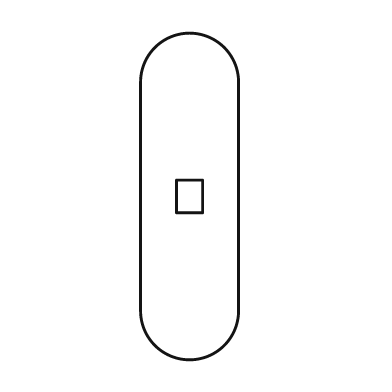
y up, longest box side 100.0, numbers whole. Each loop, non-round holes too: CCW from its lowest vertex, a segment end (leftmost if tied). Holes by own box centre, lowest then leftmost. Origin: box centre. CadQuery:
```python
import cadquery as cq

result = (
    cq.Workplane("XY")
    .moveTo(-15.0, -35.0)
    .threePointArc((0.0, -50.0), (15.0, -35.0))
    .lineTo(15.0, 35.0)
    .threePointArc((0.0, 50.0), (-15.0, 35.0))
    .close()
    .moveTo(-4.0, -5.0)
    .lineTo(4.0, -5.0)
    .lineTo(4.0, 5.0)
    .lineTo(-4.0, 5.0)
    .close()
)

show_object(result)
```